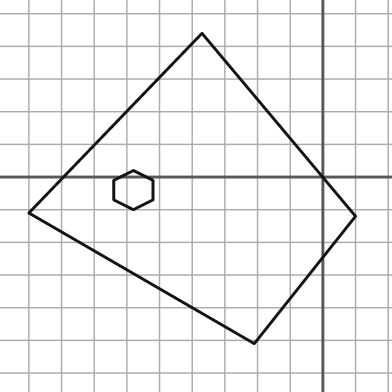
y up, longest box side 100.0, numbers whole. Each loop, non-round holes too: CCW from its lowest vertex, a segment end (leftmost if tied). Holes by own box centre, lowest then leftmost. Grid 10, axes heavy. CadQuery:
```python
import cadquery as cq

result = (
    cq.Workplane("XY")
    .moveTo(-21.0, -51.0)
    .lineTo(10.0, -12.0)
    .lineTo(-37.0, 44.0)
    .lineTo(-90.0, -11.0)
    .close()
    .moveTo(-58.0, -10.0)
    .lineTo(-52.0, -7.0)
    .lineTo(-52.0, -1.0)
    .lineTo(-58.0, 2.0)
    .lineTo(-64.0, -1.0)
    .lineTo(-64.0, -7.0)
    .close()
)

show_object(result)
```